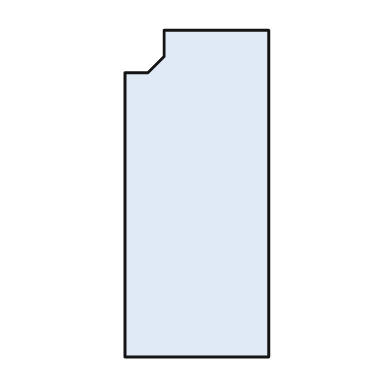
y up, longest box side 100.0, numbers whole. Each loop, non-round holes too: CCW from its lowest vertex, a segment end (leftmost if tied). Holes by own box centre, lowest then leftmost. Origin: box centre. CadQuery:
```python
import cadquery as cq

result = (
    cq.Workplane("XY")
    .moveTo(-22.0, -50.0)
    .lineTo(22.0, -50.0)
    .lineTo(22.0, 50.0)
    .lineTo(-10.0, 50.0)
    .lineTo(-10.0, 42.0)
    .lineTo(-15.0, 37.0)
    .lineTo(-22.0, 37.0)
    .close()
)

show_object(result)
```